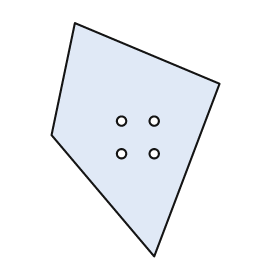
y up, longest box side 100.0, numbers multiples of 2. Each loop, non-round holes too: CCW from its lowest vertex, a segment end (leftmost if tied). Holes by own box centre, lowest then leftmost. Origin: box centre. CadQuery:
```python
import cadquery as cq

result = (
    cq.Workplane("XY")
    .moveTo(8.0, -50.0)
    .lineTo(36.0, 24.0)
    .lineTo(-26.0, 50.0)
    .lineTo(-36.0, 2.0)
    .close()
    .moveTo(-6.0, -6.0)
    .circle(2.0)
    .moveTo(8.0, -6.0)
    .circle(2.0)
    .moveTo(-6.0, 8.0)
    .circle(2.0)
    .moveTo(8.0, 8.0)
    .circle(2.0)
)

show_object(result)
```